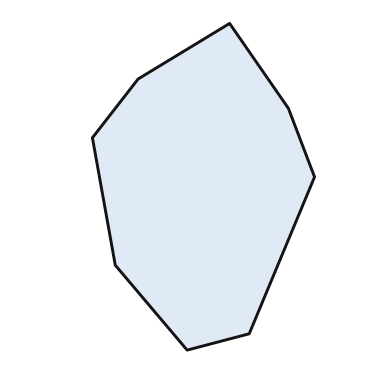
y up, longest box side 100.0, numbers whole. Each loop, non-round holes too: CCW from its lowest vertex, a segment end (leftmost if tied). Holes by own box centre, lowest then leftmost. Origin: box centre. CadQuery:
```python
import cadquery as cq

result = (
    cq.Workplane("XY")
    .moveTo(-5.0, -50.0)
    .lineTo(14.0, -45.0)
    .lineTo(34.0, 3.0)
    .lineTo(26.0, 24.0)
    .lineTo(8.0, 50.0)
    .lineTo(-20.0, 33.0)
    .lineTo(-34.0, 15.0)
    .lineTo(-27.0, -24.0)
    .close()
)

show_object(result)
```